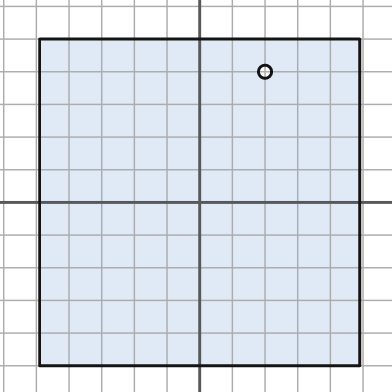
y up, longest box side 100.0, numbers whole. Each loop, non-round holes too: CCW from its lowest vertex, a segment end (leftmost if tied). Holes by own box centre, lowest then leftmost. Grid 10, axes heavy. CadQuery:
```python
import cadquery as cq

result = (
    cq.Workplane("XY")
    .moveTo(-49.0, -50.0)
    .lineTo(49.0, -50.0)
    .lineTo(49.0, 50.0)
    .lineTo(-49.0, 50.0)
    .close()
    .moveTo(20.0, 40.0)
    .circle(2.0)
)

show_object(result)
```